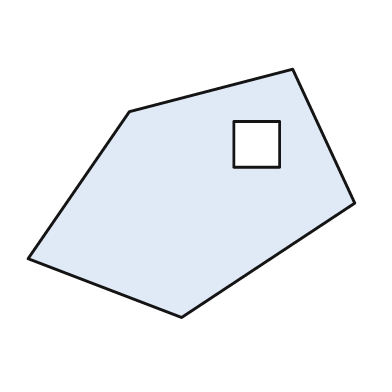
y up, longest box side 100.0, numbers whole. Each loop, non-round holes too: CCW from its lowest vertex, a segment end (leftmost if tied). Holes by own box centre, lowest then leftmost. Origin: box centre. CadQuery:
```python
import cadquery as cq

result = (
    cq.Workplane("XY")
    .moveTo(-3.0, -38.0)
    .lineTo(50.0, -3.0)
    .lineTo(31.0, 38.0)
    .lineTo(-19.0, 25.0)
    .lineTo(-50.0, -20.0)
    .close()
    .moveTo(13.0, 8.0)
    .lineTo(27.0, 8.0)
    .lineTo(27.0, 22.0)
    .lineTo(13.0, 22.0)
    .close()
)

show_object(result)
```